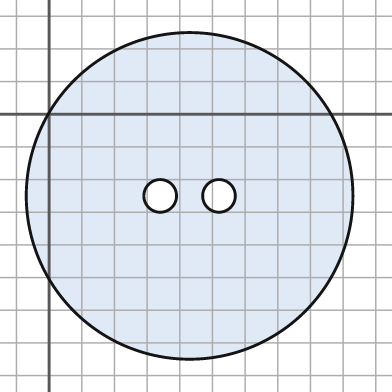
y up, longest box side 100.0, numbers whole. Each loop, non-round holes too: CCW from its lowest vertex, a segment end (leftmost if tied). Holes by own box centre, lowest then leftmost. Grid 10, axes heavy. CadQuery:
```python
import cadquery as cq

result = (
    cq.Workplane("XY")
    .moveTo(43.0, -25.0)
    .circle(50.0)
    .moveTo(34.0, -25.0)
    .circle(5.0)
    .moveTo(52.0, -25.0)
    .circle(5.0)
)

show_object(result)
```